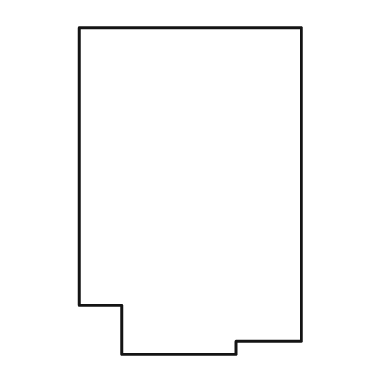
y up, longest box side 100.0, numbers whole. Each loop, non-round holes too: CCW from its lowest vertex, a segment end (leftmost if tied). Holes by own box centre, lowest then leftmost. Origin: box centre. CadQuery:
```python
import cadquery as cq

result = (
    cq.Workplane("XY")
    .moveTo(-21.0, -50.0)
    .lineTo(14.0, -50.0)
    .lineTo(14.0, -46.0)
    .lineTo(34.0, -46.0)
    .lineTo(34.0, 50.0)
    .lineTo(-34.0, 50.0)
    .lineTo(-34.0, -35.0)
    .lineTo(-21.0, -35.0)
    .close()
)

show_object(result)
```